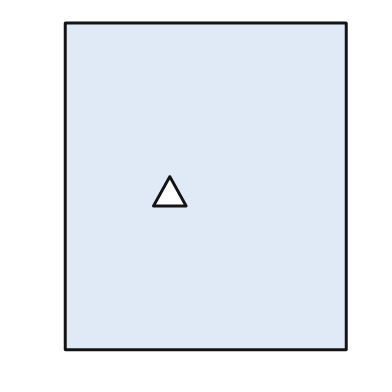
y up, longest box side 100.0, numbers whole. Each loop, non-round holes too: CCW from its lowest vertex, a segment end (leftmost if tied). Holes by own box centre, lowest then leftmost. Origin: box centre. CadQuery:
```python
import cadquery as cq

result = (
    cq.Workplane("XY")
    .moveTo(-43.0, -50.0)
    .lineTo(43.0, -50.0)
    .lineTo(43.0, 50.0)
    .lineTo(-43.0, 50.0)
    .close()
    .moveTo(-16.0, -6.0)
    .lineTo(-6.0, -6.0)
    .lineTo(-11.0, 3.0)
    .close()
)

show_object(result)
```